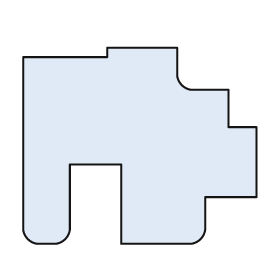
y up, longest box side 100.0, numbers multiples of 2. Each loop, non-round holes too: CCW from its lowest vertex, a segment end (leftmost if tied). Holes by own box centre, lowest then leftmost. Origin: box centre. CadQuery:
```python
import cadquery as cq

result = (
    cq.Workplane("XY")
    .moveTo(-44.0, -42.0)
    .lineTo(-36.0, -42.0)
    .threePointArc((-32.0, -40.0), (-30.0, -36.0))
    .lineTo(-30.0, -8.0)
    .lineTo(-8.0, -8.0)
    .lineTo(-8.0, -42.0)
    .lineTo(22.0, -42.0)
    .threePointArc((26.0, -40.0), (28.0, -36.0))
    .lineTo(28.0, -22.0)
    .lineTo(50.0, -22.0)
    .lineTo(50.0, 8.0)
    .lineTo(38.0, 8.0)
    .lineTo(38.0, 24.0)
    .lineTo(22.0, 24.0)
    .threePointArc((18.0, 26.0), (16.0, 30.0))
    .lineTo(16.0, 42.0)
    .lineTo(-14.0, 42.0)
    .lineTo(-14.0, 38.0)
    .lineTo(-50.0, 38.0)
    .lineTo(-50.0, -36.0)
    .threePointArc((-48.0, -40.0), (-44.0, -42.0))
    .close()
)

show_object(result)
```